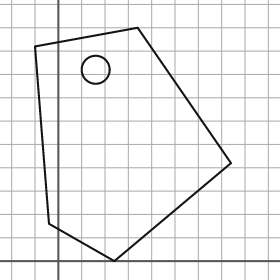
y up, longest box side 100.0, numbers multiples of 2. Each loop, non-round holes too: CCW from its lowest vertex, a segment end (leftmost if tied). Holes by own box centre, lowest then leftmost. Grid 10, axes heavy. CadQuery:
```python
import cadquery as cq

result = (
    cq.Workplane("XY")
    .moveTo(24.0, 0.0)
    .lineTo(74.0, 42.0)
    .lineTo(34.0, 100.0)
    .lineTo(-10.0, 92.0)
    .lineTo(-4.0, 16.0)
    .close()
    .moveTo(16.0, 82.0)
    .circle(6.0)
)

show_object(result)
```